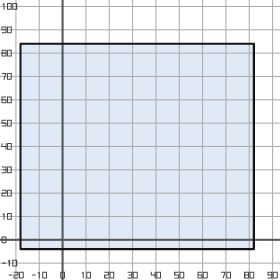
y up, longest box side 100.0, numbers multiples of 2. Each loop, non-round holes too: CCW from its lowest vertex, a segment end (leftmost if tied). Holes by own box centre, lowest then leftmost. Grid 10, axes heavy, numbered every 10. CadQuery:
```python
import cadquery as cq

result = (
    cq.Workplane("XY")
    .moveTo(-18.0, -4.0)
    .lineTo(82.0, -4.0)
    .lineTo(82.0, 84.0)
    .lineTo(-18.0, 84.0)
    .close()
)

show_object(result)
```